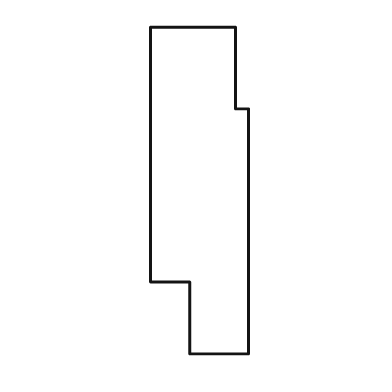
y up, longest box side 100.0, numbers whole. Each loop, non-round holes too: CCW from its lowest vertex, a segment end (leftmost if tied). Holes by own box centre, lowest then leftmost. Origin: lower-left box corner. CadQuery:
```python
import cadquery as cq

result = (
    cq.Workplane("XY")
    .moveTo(12.0, 0.0)
    .lineTo(30.0, 0.0)
    .lineTo(30.0, 75.0)
    .lineTo(26.0, 75.0)
    .lineTo(26.0, 100.0)
    .lineTo(0.0, 100.0)
    .lineTo(0.0, 22.0)
    .lineTo(12.0, 22.0)
    .close()
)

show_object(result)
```